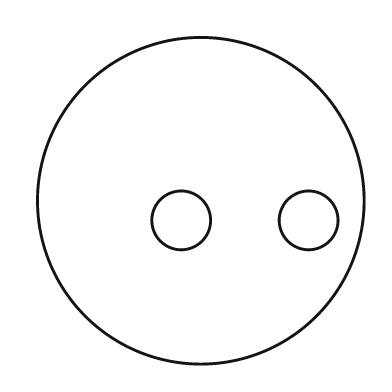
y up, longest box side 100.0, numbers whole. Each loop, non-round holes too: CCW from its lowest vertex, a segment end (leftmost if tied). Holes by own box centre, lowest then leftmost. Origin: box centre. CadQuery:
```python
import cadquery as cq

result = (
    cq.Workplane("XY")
    .moveTo(0.0, 0.0)
    .circle(50.0)
    .moveTo(-6.0, -6.0)
    .circle(9.0)
    .moveTo(33.0, -6.0)
    .circle(9.0)
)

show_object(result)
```